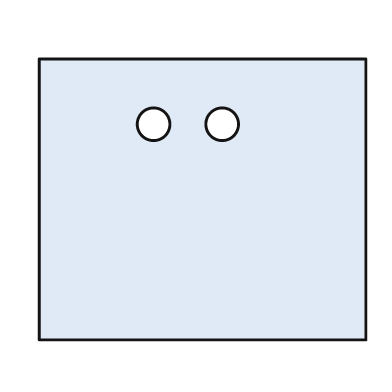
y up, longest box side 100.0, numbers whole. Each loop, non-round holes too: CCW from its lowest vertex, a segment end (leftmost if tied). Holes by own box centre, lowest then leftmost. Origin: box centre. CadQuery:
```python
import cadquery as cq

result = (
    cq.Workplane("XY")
    .moveTo(-50.0, -43.0)
    .lineTo(50.0, -43.0)
    .lineTo(50.0, 43.0)
    .lineTo(-50.0, 43.0)
    .close()
    .moveTo(-15.0, 23.0)
    .circle(5.0)
    .moveTo(6.0, 23.0)
    .circle(5.0)
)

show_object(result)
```